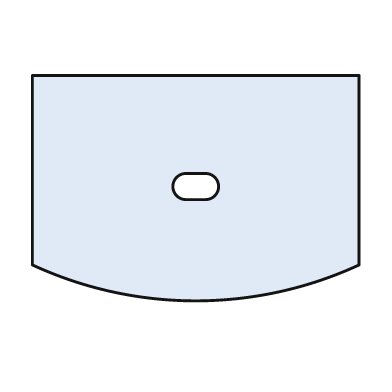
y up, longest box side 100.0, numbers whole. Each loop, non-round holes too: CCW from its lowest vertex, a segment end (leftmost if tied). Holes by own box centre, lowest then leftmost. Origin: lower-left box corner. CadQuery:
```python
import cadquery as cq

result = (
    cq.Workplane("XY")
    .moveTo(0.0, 11.0)
    .threePointArc((50.0, 0.0), (100.0, 11.0))
    .lineTo(100.0, 69.0)
    .lineTo(0.0, 69.0)
    .close()
    .moveTo(47.0, 31.0)
    .lineTo(53.0, 31.0)
    .threePointArc((57.0, 35.0), (53.0, 39.0))
    .lineTo(47.0, 39.0)
    .threePointArc((43.0, 35.0), (47.0, 31.0))
    .close()
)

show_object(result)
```